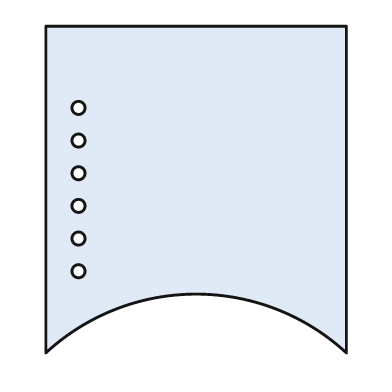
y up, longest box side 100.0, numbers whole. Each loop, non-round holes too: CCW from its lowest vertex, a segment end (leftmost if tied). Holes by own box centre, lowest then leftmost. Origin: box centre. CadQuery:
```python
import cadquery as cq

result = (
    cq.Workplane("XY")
    .moveTo(-46.0, -50.0)
    .threePointArc((0.0, -32.0), (46.0, -50.0))
    .lineTo(46.0, 50.0)
    .lineTo(-46.0, 50.0)
    .close()
    .moveTo(-36.0, -25.0)
    .circle(2.0)
    .moveTo(-36.0, -15.0)
    .circle(2.0)
    .moveTo(-36.0, -5.0)
    .circle(2.0)
    .moveTo(-36.0, 5.0)
    .circle(2.0)
    .moveTo(-36.0, 15.0)
    .circle(2.0)
    .moveTo(-36.0, 25.0)
    .circle(2.0)
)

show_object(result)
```